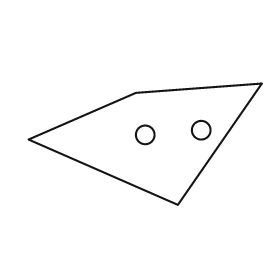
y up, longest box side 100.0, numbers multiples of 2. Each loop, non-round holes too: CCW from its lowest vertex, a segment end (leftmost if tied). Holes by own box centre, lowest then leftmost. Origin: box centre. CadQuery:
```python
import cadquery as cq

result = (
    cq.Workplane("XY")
    .moveTo(14.0, -26.0)
    .lineTo(50.0, 26.0)
    .lineTo(-4.0, 22.0)
    .lineTo(-50.0, 2.0)
    .close()
    .moveTo(0.0, 4.0)
    .circle(4.0)
    .moveTo(24.0, 6.0)
    .circle(4.0)
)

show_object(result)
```